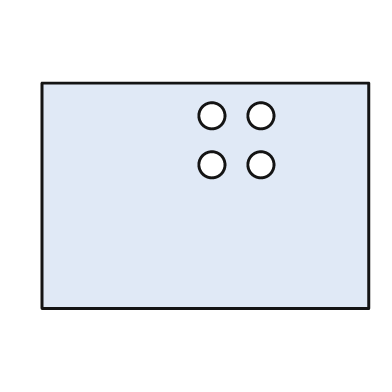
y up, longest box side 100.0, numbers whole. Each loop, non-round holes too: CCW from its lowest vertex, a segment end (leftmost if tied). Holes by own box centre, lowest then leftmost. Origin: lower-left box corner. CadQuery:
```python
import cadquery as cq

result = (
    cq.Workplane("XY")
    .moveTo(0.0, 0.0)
    .lineTo(100.0, 0.0)
    .lineTo(100.0, 69.0)
    .lineTo(0.0, 69.0)
    .close()
    .moveTo(52.0, 44.0)
    .circle(4.0)
    .moveTo(67.0, 44.0)
    .circle(4.0)
    .moveTo(52.0, 59.0)
    .circle(4.0)
    .moveTo(67.0, 59.0)
    .circle(4.0)
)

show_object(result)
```